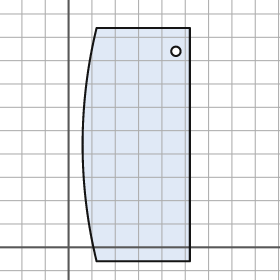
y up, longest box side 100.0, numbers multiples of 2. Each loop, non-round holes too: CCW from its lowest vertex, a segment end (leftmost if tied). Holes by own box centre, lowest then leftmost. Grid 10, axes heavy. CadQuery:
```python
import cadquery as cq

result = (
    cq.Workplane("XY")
    .moveTo(12.0, -6.0)
    .lineTo(52.0, -6.0)
    .lineTo(52.0, 94.0)
    .lineTo(12.0, 94.0)
    .threePointArc((6.0, 44.0), (12.0, -6.0))
    .close()
    .moveTo(46.0, 84.0)
    .circle(2.0)
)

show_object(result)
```